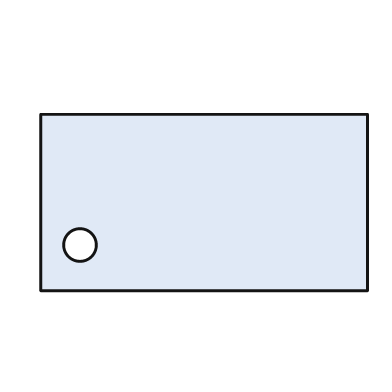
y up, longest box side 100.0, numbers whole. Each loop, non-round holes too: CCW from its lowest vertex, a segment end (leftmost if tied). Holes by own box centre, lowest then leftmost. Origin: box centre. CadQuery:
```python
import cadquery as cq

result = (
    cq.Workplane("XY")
    .moveTo(-50.0, -27.0)
    .lineTo(50.0, -27.0)
    .lineTo(50.0, 27.0)
    .lineTo(-50.0, 27.0)
    .close()
    .moveTo(-38.0, -13.0)
    .circle(5.0)
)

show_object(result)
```